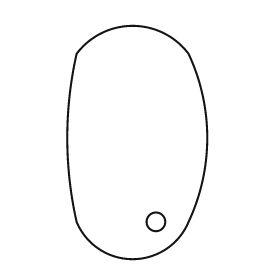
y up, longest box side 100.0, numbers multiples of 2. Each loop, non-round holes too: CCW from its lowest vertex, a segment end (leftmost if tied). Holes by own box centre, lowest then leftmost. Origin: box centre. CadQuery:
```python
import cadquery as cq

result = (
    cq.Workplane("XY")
    .moveTo(-26.0, -34.0)
    .threePointArc((-2.0, -50.0), (22.0, -34.0))
    .threePointArc((30.0, 2.0), (22.0, 38.0))
    .threePointArc((-2.0, 50.0), (-26.0, 38.0))
    .threePointArc((-30.0, 2.0), (-26.0, -34.0))
    .close()
    .moveTo(8.0, -34.0)
    .circle(4.0)
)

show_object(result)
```